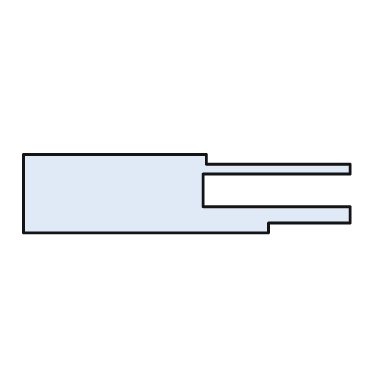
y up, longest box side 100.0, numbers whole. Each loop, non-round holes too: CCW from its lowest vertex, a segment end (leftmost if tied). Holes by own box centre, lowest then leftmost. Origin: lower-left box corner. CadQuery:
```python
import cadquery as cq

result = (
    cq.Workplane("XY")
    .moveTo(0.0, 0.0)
    .lineTo(75.0, 0.0)
    .lineTo(75.0, 3.0)
    .lineTo(100.0, 3.0)
    .lineTo(100.0, 8.0)
    .lineTo(55.0, 8.0)
    .lineTo(55.0, 18.0)
    .lineTo(100.0, 18.0)
    .lineTo(100.0, 21.0)
    .lineTo(56.0, 21.0)
    .lineTo(56.0, 24.0)
    .lineTo(0.0, 24.0)
    .close()
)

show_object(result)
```